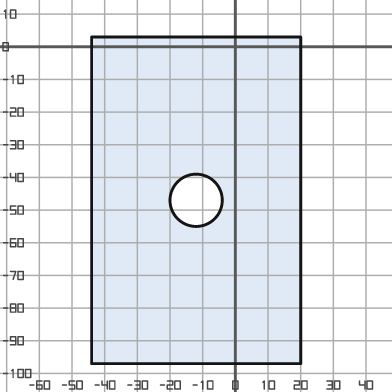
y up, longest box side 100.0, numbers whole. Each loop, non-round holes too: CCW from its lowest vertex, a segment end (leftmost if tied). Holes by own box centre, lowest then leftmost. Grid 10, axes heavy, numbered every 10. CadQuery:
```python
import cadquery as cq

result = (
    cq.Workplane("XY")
    .moveTo(-44.0, -97.0)
    .lineTo(20.0, -97.0)
    .lineTo(20.0, 3.0)
    .lineTo(-44.0, 3.0)
    .close()
    .moveTo(-12.0, -47.0)
    .circle(8.0)
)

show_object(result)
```